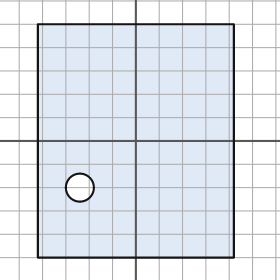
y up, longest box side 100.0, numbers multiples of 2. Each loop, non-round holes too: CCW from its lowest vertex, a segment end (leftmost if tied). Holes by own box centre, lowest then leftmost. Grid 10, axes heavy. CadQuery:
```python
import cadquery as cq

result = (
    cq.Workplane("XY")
    .moveTo(-42.0, -50.0)
    .lineTo(42.0, -50.0)
    .lineTo(42.0, 50.0)
    .lineTo(-42.0, 50.0)
    .close()
    .moveTo(-24.0, -20.0)
    .circle(6.0)
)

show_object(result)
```